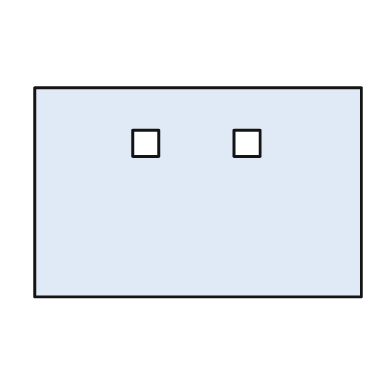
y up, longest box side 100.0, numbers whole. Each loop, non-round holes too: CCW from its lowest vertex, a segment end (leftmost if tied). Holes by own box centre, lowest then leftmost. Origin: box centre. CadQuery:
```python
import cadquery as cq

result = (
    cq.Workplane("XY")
    .moveTo(-50.0, -32.0)
    .lineTo(50.0, -32.0)
    .lineTo(50.0, 32.0)
    .lineTo(-50.0, 32.0)
    .close()
    .moveTo(-20.0, 11.0)
    .lineTo(-12.0, 11.0)
    .lineTo(-12.0, 19.0)
    .lineTo(-20.0, 19.0)
    .close()
    .moveTo(11.0, 11.0)
    .lineTo(19.0, 11.0)
    .lineTo(19.0, 19.0)
    .lineTo(11.0, 19.0)
    .close()
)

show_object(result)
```